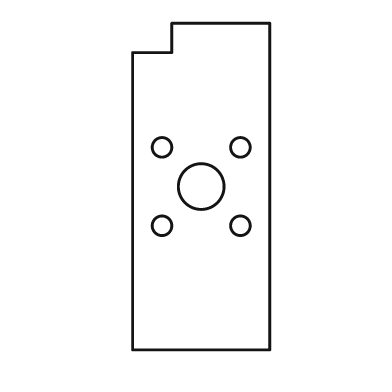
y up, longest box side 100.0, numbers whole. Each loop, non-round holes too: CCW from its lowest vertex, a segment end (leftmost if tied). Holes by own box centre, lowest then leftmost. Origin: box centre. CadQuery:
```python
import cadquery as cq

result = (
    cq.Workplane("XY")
    .moveTo(-21.0, -50.0)
    .lineTo(21.0, -50.0)
    .lineTo(21.0, 50.0)
    .lineTo(-9.0, 50.0)
    .lineTo(-9.0, 41.0)
    .lineTo(-21.0, 41.0)
    .close()
    .moveTo(-12.0, -12.0)
    .circle(3.0)
    .moveTo(12.0, -12.0)
    .circle(3.0)
    .moveTo(0.0, 0.0)
    .circle(7.0)
    .moveTo(-12.0, 12.0)
    .circle(3.0)
    .moveTo(12.0, 12.0)
    .circle(3.0)
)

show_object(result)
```